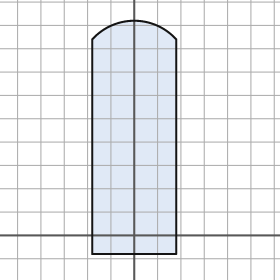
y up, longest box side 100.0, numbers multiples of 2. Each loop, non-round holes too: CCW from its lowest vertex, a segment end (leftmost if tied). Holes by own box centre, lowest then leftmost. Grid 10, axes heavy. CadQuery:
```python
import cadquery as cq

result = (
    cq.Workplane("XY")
    .moveTo(-18.0, -8.0)
    .lineTo(18.0, -8.0)
    .lineTo(18.0, 84.0)
    .threePointArc((0.0, 92.0), (-18.0, 84.0))
    .close()
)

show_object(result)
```